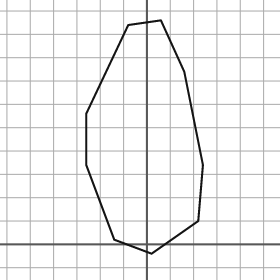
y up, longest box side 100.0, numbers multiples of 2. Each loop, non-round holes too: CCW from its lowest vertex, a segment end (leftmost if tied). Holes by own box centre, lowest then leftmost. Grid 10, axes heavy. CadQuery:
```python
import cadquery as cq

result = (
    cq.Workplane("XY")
    .moveTo(2.0, -4.0)
    .lineTo(22.0, 10.0)
    .lineTo(24.0, 34.0)
    .lineTo(16.0, 74.0)
    .lineTo(6.0, 96.0)
    .lineTo(-8.0, 94.0)
    .lineTo(-26.0, 56.0)
    .lineTo(-26.0, 34.0)
    .lineTo(-14.0, 2.0)
    .close()
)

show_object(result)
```